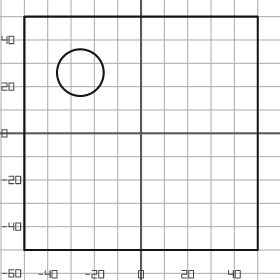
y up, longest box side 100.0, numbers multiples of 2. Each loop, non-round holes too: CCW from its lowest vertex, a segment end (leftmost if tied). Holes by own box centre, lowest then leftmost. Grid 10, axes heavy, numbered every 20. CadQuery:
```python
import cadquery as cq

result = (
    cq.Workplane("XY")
    .moveTo(-50.0, -50.0)
    .lineTo(50.0, -50.0)
    .lineTo(50.0, 50.0)
    .lineTo(-50.0, 50.0)
    .close()
    .moveTo(-26.0, 26.0)
    .circle(10.0)
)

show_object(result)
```